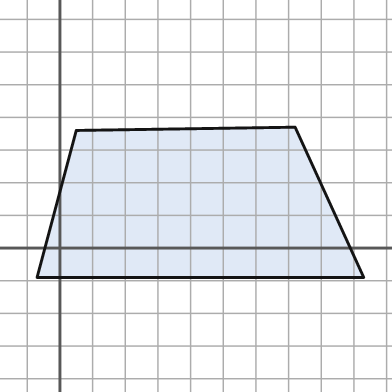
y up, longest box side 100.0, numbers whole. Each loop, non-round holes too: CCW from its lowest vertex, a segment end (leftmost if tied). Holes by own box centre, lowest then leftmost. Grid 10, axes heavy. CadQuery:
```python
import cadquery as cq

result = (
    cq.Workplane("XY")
    .moveTo(-7.0, -9.0)
    .lineTo(93.0, -9.0)
    .lineTo(72.0, 37.0)
    .lineTo(5.0, 36.0)
    .close()
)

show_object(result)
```